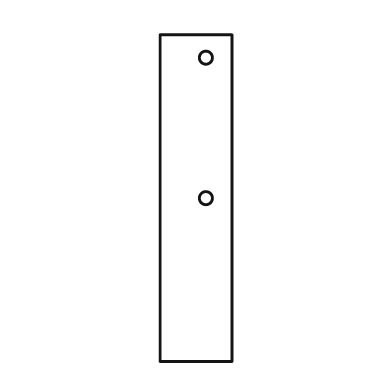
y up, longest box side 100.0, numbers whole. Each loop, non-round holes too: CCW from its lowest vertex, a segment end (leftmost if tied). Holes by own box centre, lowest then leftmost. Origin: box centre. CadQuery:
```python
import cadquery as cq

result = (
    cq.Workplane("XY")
    .moveTo(-11.0, -50.0)
    .lineTo(11.0, -50.0)
    .lineTo(11.0, 50.0)
    .lineTo(-11.0, 50.0)
    .close()
    .moveTo(3.0, 0.0)
    .circle(2.0)
    .moveTo(3.0, 43.0)
    .circle(2.0)
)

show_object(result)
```